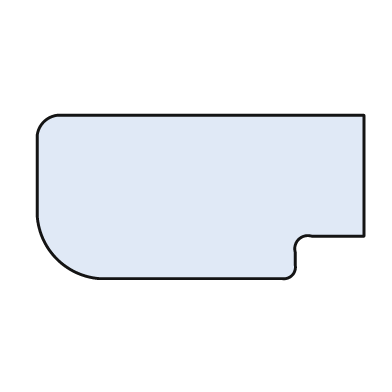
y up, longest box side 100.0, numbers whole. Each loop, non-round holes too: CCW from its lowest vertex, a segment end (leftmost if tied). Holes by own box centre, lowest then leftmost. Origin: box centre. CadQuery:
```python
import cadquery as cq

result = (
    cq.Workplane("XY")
    .moveTo(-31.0, -25.0)
    .lineTo(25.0, -25.0)
    .threePointArc((28.0, -24.0), (29.0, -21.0))
    .lineTo(29.0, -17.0)
    .threePointArc((30.0, -13.0), (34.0, -12.0))
    .lineTo(50.0, -12.0)
    .lineTo(50.0, 25.0)
    .lineTo(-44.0, 25.0)
    .threePointArc((-48.0, 23.0), (-50.0, 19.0))
    .lineTo(-50.0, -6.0)
    .threePointArc((-44.0, -19.0), (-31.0, -25.0))
    .close()
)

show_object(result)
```